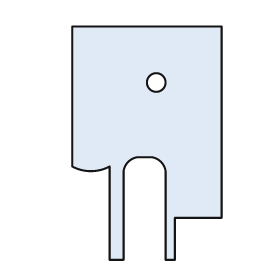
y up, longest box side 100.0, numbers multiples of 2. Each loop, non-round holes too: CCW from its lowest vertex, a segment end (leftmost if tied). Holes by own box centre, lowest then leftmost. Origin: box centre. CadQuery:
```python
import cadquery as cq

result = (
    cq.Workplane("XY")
    .moveTo(-16.0, -50.0)
    .lineTo(-10.0, -50.0)
    .lineTo(-10.0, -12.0)
    .threePointArc((-8.0, -8.0), (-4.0, -6.0))
    .lineTo(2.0, -6.0)
    .threePointArc((6.0, -8.0), (8.0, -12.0))
    .lineTo(8.0, -50.0)
    .lineTo(12.0, -50.0)
    .lineTo(12.0, -32.0)
    .lineTo(32.0, -32.0)
    .lineTo(32.0, 50.0)
    .lineTo(-32.0, 50.0)
    .lineTo(-32.0, -10.0)
    .threePointArc((-24.0, -12.0), (-16.0, -10.0))
    .close()
    .moveTo(4.0, 26.0)
    .circle(4.0)
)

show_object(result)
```